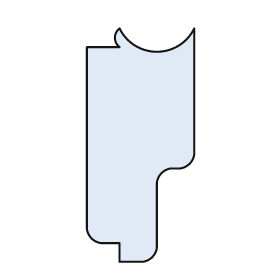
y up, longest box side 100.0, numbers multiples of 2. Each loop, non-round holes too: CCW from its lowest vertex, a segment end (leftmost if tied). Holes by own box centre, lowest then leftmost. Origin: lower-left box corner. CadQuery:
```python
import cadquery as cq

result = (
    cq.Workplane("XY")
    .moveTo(14.0, 0.0)
    .lineTo(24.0, 0.0)
    .threePointArc((28.0, 2.0), (30.0, 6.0))
    .lineTo(30.0, 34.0)
    .threePointArc((32.0, 38.0), (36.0, 40.0))
    .lineTo(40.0, 40.0)
    .threePointArc((44.0, 42.0), (46.0, 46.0))
    .lineTo(46.0, 100.0)
    .threePointArc((30.0, 90.0), (14.0, 100.0))
    .threePointArc((12.0, 96.0), (14.0, 92.0))
    .lineTo(0.0, 92.0)
    .lineTo(0.0, 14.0)
    .threePointArc((2.0, 10.0), (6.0, 8.0))
    .lineTo(14.0, 8.0)
    .close()
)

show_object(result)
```